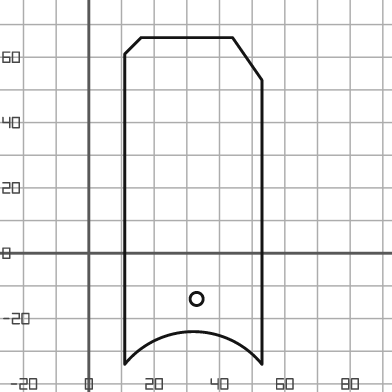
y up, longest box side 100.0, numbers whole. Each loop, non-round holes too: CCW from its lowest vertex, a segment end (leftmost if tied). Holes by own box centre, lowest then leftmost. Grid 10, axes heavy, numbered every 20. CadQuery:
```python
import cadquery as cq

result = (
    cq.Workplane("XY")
    .moveTo(11.0, -34.0)
    .threePointArc((32.0, -24.0), (53.0, -34.0))
    .lineTo(53.0, 53.0)
    .lineTo(44.0, 66.0)
    .lineTo(16.0, 66.0)
    .lineTo(11.0, 61.0)
    .close()
    .moveTo(33.0, -14.0)
    .circle(2.0)
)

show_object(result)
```